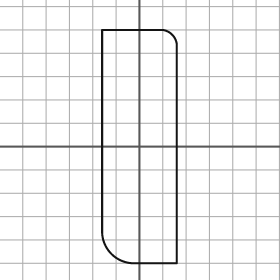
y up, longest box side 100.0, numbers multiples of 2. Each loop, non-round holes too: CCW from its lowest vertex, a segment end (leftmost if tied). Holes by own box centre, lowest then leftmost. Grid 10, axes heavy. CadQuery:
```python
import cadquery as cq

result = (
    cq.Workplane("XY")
    .moveTo(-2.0, -50.0)
    .lineTo(16.0, -50.0)
    .lineTo(16.0, 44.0)
    .threePointArc((14.0, 48.0), (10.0, 50.0))
    .lineTo(-16.0, 50.0)
    .lineTo(-16.0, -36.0)
    .threePointArc((-12.0, -46.0), (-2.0, -50.0))
    .close()
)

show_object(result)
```